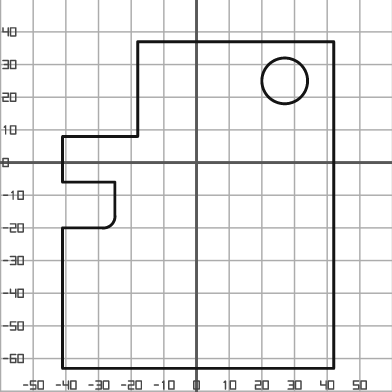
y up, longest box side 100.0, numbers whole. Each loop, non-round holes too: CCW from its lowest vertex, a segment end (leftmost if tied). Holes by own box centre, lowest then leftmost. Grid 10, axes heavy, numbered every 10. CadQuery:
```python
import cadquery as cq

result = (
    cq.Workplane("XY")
    .moveTo(-41.0, -63.0)
    .lineTo(42.0, -63.0)
    .lineTo(42.0, 37.0)
    .lineTo(-18.0, 37.0)
    .lineTo(-18.0, 8.0)
    .lineTo(-41.0, 8.0)
    .lineTo(-41.0, -6.0)
    .lineTo(-25.0, -6.0)
    .lineTo(-25.0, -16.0)
    .threePointArc((-26.0, -19.0), (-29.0, -20.0))
    .lineTo(-41.0, -20.0)
    .close()
    .moveTo(27.0, 25.0)
    .circle(7.0)
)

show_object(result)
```